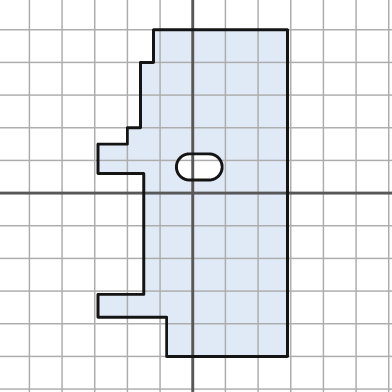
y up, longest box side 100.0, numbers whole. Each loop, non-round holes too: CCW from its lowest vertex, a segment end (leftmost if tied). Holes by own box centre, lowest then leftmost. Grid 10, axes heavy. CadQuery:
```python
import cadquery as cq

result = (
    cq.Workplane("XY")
    .moveTo(-8.0, -50.0)
    .lineTo(29.0, -50.0)
    .lineTo(29.0, 50.0)
    .lineTo(-12.0, 50.0)
    .lineTo(-12.0, 40.0)
    .lineTo(-16.0, 40.0)
    .lineTo(-16.0, 20.0)
    .lineTo(-20.0, 20.0)
    .lineTo(-20.0, 15.0)
    .lineTo(-29.0, 15.0)
    .lineTo(-29.0, 6.0)
    .lineTo(-15.0, 6.0)
    .lineTo(-15.0, -31.0)
    .lineTo(-29.0, -31.0)
    .lineTo(-29.0, -38.0)
    .lineTo(-8.0, -38.0)
    .close()
    .moveTo(-1.0, 4.0)
    .lineTo(5.0, 4.0)
    .threePointArc((9.0, 8.0), (5.0, 12.0))
    .lineTo(-1.0, 12.0)
    .threePointArc((-5.0, 8.0), (-1.0, 4.0))
    .close()
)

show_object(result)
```